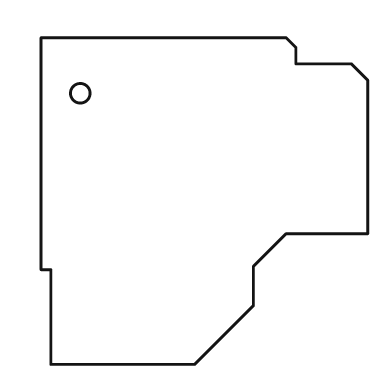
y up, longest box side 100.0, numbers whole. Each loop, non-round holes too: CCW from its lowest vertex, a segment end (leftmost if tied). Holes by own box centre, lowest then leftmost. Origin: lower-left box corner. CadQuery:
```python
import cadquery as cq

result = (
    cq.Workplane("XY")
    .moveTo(3.0, 0.0)
    .lineTo(47.0, 0.0)
    .lineTo(65.0, 18.0)
    .lineTo(65.0, 30.0)
    .lineTo(75.0, 40.0)
    .lineTo(100.0, 40.0)
    .lineTo(100.0, 87.0)
    .lineTo(95.0, 92.0)
    .lineTo(78.0, 92.0)
    .lineTo(78.0, 97.0)
    .lineTo(75.0, 100.0)
    .lineTo(0.0, 100.0)
    .lineTo(0.0, 29.0)
    .lineTo(3.0, 29.0)
    .close()
    .moveTo(12.0, 83.0)
    .circle(3.0)
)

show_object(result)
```